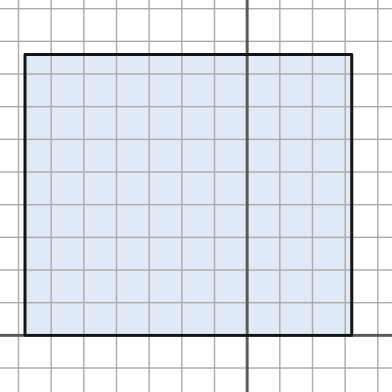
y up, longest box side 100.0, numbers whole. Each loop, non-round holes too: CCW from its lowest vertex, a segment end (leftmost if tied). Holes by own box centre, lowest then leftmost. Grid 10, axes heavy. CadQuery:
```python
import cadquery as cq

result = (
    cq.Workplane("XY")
    .moveTo(-68.0, 0.0)
    .lineTo(32.0, 0.0)
    .lineTo(32.0, 86.0)
    .lineTo(-68.0, 86.0)
    .close()
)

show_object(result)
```